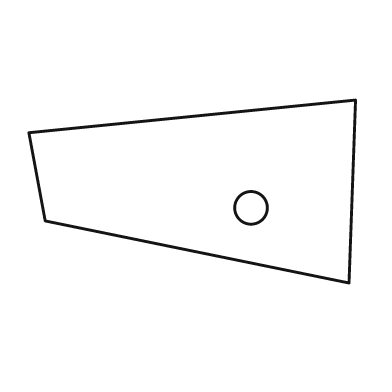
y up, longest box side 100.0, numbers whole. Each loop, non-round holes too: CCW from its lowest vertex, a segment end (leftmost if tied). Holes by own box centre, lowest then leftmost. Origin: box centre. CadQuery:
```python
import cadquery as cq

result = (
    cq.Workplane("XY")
    .moveTo(48.0, -28.0)
    .lineTo(50.0, 28.0)
    .lineTo(-50.0, 18.0)
    .lineTo(-45.0, -9.0)
    .close()
    .moveTo(18.0, -5.0)
    .circle(5.0)
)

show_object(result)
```